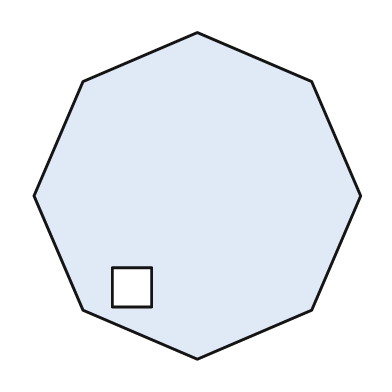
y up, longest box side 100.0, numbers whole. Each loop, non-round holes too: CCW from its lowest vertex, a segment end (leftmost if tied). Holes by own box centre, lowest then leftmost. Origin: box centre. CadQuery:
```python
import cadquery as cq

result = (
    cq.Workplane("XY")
    .moveTo(0.0, -50.0)
    .lineTo(35.0, -35.0)
    .lineTo(50.0, 0.0)
    .lineTo(35.0, 35.0)
    .lineTo(0.0, 50.0)
    .lineTo(-35.0, 35.0)
    .lineTo(-50.0, 0.0)
    .lineTo(-35.0, -35.0)
    .close()
    .moveTo(-26.0, -34.0)
    .lineTo(-14.0, -34.0)
    .lineTo(-14.0, -22.0)
    .lineTo(-26.0, -22.0)
    .close()
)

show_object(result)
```